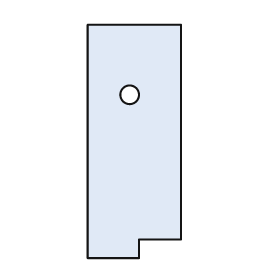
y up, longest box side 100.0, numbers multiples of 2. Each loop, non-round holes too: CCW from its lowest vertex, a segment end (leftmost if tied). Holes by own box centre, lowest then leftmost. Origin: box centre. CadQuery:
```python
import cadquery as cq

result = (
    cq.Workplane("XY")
    .moveTo(-20.0, -50.0)
    .lineTo(2.0, -50.0)
    .lineTo(2.0, -42.0)
    .lineTo(20.0, -42.0)
    .lineTo(20.0, 50.0)
    .lineTo(-20.0, 50.0)
    .close()
    .moveTo(-2.0, 20.0)
    .circle(4.0)
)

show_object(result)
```